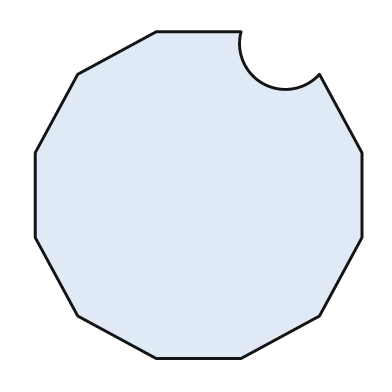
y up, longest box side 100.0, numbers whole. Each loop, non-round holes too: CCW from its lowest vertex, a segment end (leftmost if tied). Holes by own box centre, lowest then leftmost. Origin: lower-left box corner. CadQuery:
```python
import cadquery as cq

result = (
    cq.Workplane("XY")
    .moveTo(37.0, 0.0)
    .lineTo(63.0, 0.0)
    .lineTo(87.0, 13.0)
    .lineTo(100.0, 37.0)
    .lineTo(100.0, 63.0)
    .lineTo(87.0, 87.0)
    .threePointArc((70.0, 84.0), (63.0, 100.0))
    .lineTo(37.0, 100.0)
    .lineTo(13.0, 87.0)
    .lineTo(0.0, 63.0)
    .lineTo(0.0, 37.0)
    .lineTo(13.0, 13.0)
    .close()
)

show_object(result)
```